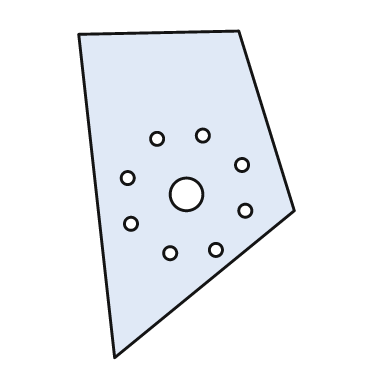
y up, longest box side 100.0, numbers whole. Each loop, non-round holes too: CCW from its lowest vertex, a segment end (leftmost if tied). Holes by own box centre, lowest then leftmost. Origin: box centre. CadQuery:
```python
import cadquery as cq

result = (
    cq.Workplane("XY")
    .moveTo(-22.0, -50.0)
    .lineTo(33.0, -5.0)
    .lineTo(16.0, 50.0)
    .lineTo(-33.0, 49.0)
    .close()
    .moveTo(-5.0, -18.0)
    .circle(2.0)
    .moveTo(9.0, -17.0)
    .circle(2.0)
    .moveTo(-17.0, -9.0)
    .circle(2.0)
    .moveTo(18.0, -5.0)
    .circle(2.0)
    .moveTo(0.0, 0.0)
    .circle(5.0)
    .moveTo(-18.0, 5.0)
    .circle(2.0)
    .moveTo(17.0, 9.0)
    .circle(2.0)
    .moveTo(-9.0, 17.0)
    .circle(2.0)
    .moveTo(5.0, 18.0)
    .circle(2.0)
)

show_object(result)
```